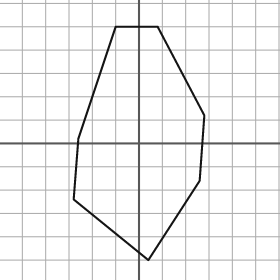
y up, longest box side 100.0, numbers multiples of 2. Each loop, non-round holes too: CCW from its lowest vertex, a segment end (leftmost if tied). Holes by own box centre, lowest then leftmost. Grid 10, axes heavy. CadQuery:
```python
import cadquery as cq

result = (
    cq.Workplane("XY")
    .moveTo(4.0, -50.0)
    .lineTo(26.0, -16.0)
    .lineTo(28.0, 12.0)
    .lineTo(8.0, 50.0)
    .lineTo(-10.0, 50.0)
    .lineTo(-26.0, 2.0)
    .lineTo(-28.0, -24.0)
    .close()
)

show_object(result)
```